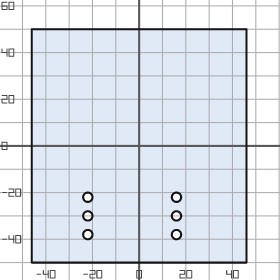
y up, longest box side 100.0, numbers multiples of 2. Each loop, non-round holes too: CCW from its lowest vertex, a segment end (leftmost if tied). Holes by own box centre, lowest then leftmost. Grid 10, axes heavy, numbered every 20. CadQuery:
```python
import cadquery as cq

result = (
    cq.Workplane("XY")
    .moveTo(-46.0, -50.0)
    .lineTo(46.0, -50.0)
    .lineTo(46.0, 50.0)
    .lineTo(-46.0, 50.0)
    .close()
    .moveTo(-22.0, -38.0)
    .circle(2.0)
    .moveTo(16.0, -38.0)
    .circle(2.0)
    .moveTo(-22.0, -30.0)
    .circle(2.0)
    .moveTo(16.0, -30.0)
    .circle(2.0)
    .moveTo(-22.0, -22.0)
    .circle(2.0)
    .moveTo(16.0, -22.0)
    .circle(2.0)
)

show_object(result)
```